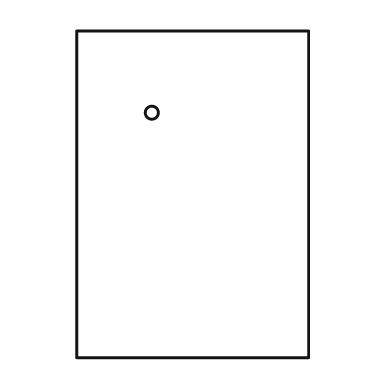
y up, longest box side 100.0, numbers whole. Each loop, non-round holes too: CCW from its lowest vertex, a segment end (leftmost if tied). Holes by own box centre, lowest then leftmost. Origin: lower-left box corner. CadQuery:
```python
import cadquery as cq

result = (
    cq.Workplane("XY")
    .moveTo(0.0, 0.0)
    .lineTo(71.0, 0.0)
    .lineTo(71.0, 100.0)
    .lineTo(0.0, 100.0)
    .close()
    .moveTo(23.0, 75.0)
    .circle(2.0)
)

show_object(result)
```